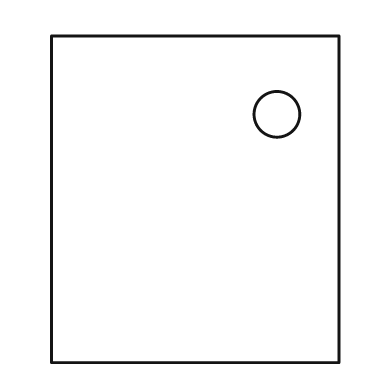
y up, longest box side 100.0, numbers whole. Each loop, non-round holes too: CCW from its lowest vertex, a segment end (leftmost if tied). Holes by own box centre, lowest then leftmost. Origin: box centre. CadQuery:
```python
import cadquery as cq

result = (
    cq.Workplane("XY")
    .moveTo(-44.0, -50.0)
    .lineTo(44.0, -50.0)
    .lineTo(44.0, 50.0)
    .lineTo(-44.0, 50.0)
    .close()
    .moveTo(25.0, 26.0)
    .circle(7.0)
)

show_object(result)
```